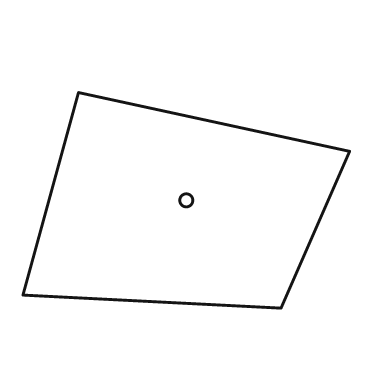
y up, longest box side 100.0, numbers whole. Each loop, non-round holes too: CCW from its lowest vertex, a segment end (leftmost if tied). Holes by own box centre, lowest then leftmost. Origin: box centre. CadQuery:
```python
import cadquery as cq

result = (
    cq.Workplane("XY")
    .moveTo(29.0, -33.0)
    .lineTo(50.0, 15.0)
    .lineTo(-33.0, 33.0)
    .lineTo(-50.0, -29.0)
    .close()
    .moveTo(0.0, 0.0)
    .circle(2.0)
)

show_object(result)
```